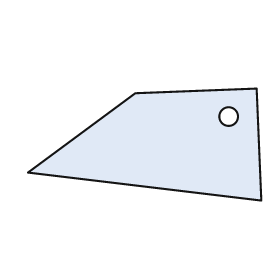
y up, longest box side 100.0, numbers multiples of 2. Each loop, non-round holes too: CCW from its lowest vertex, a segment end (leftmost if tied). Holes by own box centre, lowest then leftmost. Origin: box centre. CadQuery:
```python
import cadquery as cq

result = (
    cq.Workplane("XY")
    .moveTo(50.0, -24.0)
    .lineTo(48.0, 24.0)
    .lineTo(-4.0, 22.0)
    .lineTo(-50.0, -12.0)
    .close()
    .moveTo(36.0, 12.0)
    .circle(4.0)
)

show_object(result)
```